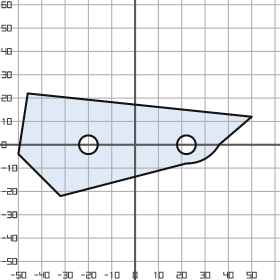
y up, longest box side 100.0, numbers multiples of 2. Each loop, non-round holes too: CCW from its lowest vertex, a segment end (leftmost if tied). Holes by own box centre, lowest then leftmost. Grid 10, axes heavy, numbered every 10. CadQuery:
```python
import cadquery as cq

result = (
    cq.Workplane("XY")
    .moveTo(-32.0, -22.0)
    .lineTo(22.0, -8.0)
    .threePointArc((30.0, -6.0), (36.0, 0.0))
    .lineTo(50.0, 12.0)
    .lineTo(-46.0, 22.0)
    .lineTo(-50.0, -4.0)
    .close()
    .moveTo(-20.0, 0.0)
    .circle(4.0)
    .moveTo(22.0, 0.0)
    .circle(4.0)
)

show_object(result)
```